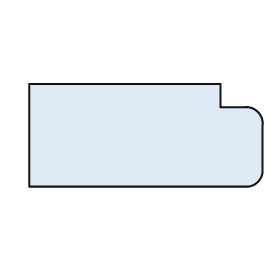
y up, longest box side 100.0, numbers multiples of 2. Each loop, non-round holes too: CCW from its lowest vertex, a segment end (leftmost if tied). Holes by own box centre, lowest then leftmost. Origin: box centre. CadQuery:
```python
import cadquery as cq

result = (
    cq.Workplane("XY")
    .moveTo(-50.0, -22.0)
    .lineTo(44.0, -22.0)
    .threePointArc((48.0, -20.0), (50.0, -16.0))
    .lineTo(50.0, 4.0)
    .threePointArc((48.0, 10.0), (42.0, 12.0))
    .lineTo(32.0, 12.0)
    .lineTo(32.0, 22.0)
    .lineTo(-50.0, 22.0)
    .close()
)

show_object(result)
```